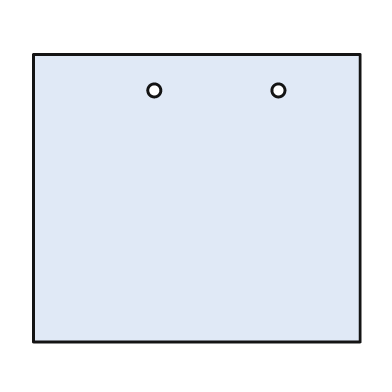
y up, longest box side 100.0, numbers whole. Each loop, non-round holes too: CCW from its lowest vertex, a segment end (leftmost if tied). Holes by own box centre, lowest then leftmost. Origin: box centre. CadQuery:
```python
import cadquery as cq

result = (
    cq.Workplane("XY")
    .moveTo(-50.0, -44.0)
    .lineTo(50.0, -44.0)
    .lineTo(50.0, 44.0)
    .lineTo(-50.0, 44.0)
    .close()
    .moveTo(-13.0, 33.0)
    .circle(2.0)
    .moveTo(25.0, 33.0)
    .circle(2.0)
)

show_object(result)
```